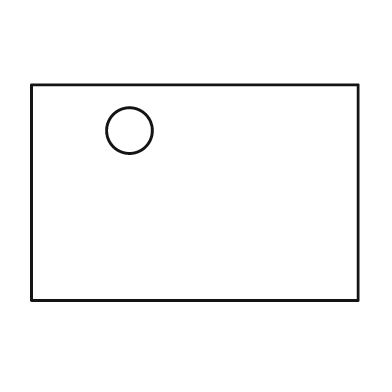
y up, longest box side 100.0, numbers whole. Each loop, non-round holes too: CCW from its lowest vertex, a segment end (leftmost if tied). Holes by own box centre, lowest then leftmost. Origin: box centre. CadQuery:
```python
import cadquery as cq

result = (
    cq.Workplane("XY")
    .moveTo(-50.0, -33.0)
    .lineTo(50.0, -33.0)
    .lineTo(50.0, 33.0)
    .lineTo(-50.0, 33.0)
    .close()
    .moveTo(-20.0, 19.0)
    .circle(7.0)
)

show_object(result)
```